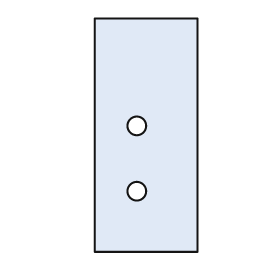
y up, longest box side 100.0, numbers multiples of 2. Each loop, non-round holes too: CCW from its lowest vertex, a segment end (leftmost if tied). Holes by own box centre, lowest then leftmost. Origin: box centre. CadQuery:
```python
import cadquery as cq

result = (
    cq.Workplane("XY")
    .moveTo(-22.0, -50.0)
    .lineTo(22.0, -50.0)
    .lineTo(22.0, 50.0)
    .lineTo(-22.0, 50.0)
    .close()
    .moveTo(-4.0, -24.0)
    .circle(4.0)
    .moveTo(-4.0, 4.0)
    .circle(4.0)
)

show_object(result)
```